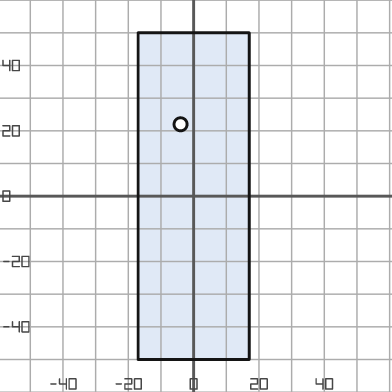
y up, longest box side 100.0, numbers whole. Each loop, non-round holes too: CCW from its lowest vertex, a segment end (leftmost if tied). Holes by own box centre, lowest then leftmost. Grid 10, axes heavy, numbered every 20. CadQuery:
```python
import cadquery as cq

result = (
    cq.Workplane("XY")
    .moveTo(-17.0, -50.0)
    .lineTo(17.0, -50.0)
    .lineTo(17.0, 50.0)
    .lineTo(-17.0, 50.0)
    .close()
    .moveTo(-4.0, 22.0)
    .circle(2.0)
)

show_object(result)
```